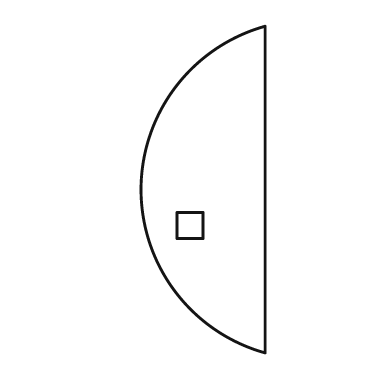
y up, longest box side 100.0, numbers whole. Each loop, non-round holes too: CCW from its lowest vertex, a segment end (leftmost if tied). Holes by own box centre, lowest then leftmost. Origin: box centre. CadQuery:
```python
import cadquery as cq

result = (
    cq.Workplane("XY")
    .moveTo(19.0, -50.0)
    .lineTo(19.0, 50.0)
    .threePointArc((-19.0, 0.0), (19.0, -50.0))
    .close()
    .moveTo(-8.0, -15.0)
    .lineTo(0.0, -15.0)
    .lineTo(0.0, -7.0)
    .lineTo(-8.0, -7.0)
    .close()
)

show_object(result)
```